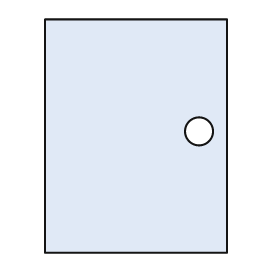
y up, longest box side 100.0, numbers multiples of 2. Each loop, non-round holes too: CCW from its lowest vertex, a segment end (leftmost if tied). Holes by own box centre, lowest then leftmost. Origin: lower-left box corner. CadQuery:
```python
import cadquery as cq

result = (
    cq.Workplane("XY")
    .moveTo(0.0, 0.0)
    .lineTo(78.0, 0.0)
    .lineTo(78.0, 100.0)
    .lineTo(0.0, 100.0)
    .close()
    .moveTo(66.0, 52.0)
    .circle(6.0)
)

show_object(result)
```